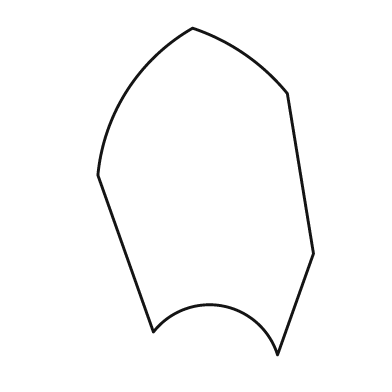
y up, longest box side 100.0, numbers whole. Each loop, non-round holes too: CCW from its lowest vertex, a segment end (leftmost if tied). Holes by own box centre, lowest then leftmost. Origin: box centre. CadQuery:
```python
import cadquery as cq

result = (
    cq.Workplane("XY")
    .moveTo(22.0, -50.0)
    .lineTo(33.0, -19.0)
    .lineTo(25.0, 30.0)
    .threePointArc((12.0, 42.0), (-4.0, 50.0))
    .threePointArc((-24.0, 31.0), (-33.0, 5.0))
    .lineTo(-16.0, -43.0)
    .threePointArc((5.0, -35.0), (22.0, -50.0))
    .close()
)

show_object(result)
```